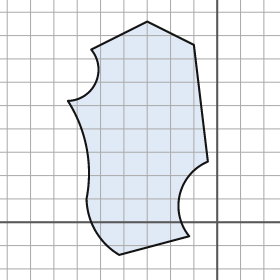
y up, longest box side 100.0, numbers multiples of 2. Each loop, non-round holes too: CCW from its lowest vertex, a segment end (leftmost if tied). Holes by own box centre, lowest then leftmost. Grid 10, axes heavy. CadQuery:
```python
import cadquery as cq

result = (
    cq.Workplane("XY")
    .moveTo(-42.0, -14.0)
    .lineTo(-12.0, -6.0)
    .threePointArc((-16.0, 12.0), (-4.0, 26.0))
    .lineTo(-10.0, 76.0)
    .lineTo(-30.0, 86.0)
    .lineTo(-54.0, 74.0)
    .threePointArc((-52.0, 60.0), (-64.0, 52.0))
    .threePointArc((-56.0, 32.0), (-56.0, 10.0))
    .threePointArc((-52.0, -4.0), (-42.0, -14.0))
    .close()
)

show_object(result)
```